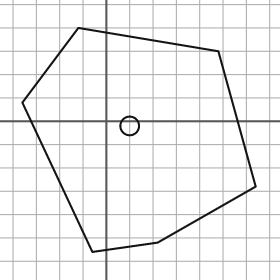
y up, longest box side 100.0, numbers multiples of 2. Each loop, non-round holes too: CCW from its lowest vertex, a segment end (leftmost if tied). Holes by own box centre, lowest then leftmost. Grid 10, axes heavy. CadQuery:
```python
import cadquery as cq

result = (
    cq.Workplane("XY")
    .moveTo(-6.0, -56.0)
    .lineTo(22.0, -52.0)
    .lineTo(64.0, -28.0)
    .lineTo(48.0, 30.0)
    .lineTo(-12.0, 40.0)
    .lineTo(-36.0, 8.0)
    .close()
    .moveTo(10.0, -2.0)
    .circle(4.0)
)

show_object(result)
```